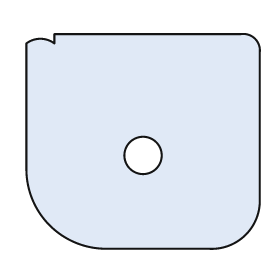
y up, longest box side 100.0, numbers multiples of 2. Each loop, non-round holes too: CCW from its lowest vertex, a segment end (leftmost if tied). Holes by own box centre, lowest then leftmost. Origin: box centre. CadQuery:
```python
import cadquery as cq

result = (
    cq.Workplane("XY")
    .moveTo(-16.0, -46.0)
    .lineTo(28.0, -46.0)
    .threePointArc((44.0, -40.0), (50.0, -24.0))
    .lineTo(50.0, 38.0)
    .threePointArc((48.0, 44.0), (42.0, 46.0))
    .lineTo(-38.0, 46.0)
    .lineTo(-38.0, 42.0)
    .threePointArc((-44.0, 44.0), (-50.0, 42.0))
    .lineTo(-50.0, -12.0)
    .threePointArc((-40.0, -36.0), (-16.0, -46.0))
    .close()
    .moveTo(0.0, -6.0)
    .circle(8.0)
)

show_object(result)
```